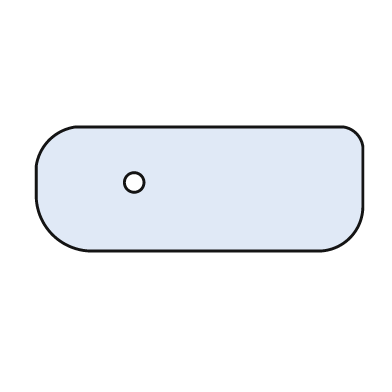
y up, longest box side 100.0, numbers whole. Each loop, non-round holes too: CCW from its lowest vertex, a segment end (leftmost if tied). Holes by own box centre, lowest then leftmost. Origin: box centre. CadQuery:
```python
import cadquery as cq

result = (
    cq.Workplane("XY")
    .moveTo(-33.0, -19.0)
    .lineTo(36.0, -19.0)
    .threePointArc((46.0, -15.0), (50.0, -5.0))
    .lineTo(50.0, 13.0)
    .threePointArc((48.0, 17.0), (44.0, 19.0))
    .lineTo(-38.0, 19.0)
    .threePointArc((-46.0, 15.0), (-50.0, 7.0))
    .lineTo(-50.0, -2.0)
    .threePointArc((-45.0, -14.0), (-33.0, -19.0))
    .close()
    .moveTo(-20.0, 2.0)
    .circle(3.0)
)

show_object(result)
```